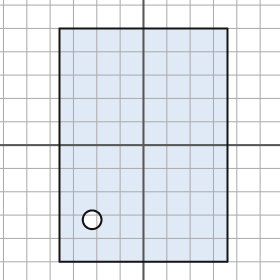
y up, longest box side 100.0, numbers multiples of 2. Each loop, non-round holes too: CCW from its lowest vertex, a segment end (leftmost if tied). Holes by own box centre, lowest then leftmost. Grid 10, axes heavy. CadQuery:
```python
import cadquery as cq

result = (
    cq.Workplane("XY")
    .moveTo(-36.0, -50.0)
    .lineTo(36.0, -50.0)
    .lineTo(36.0, 50.0)
    .lineTo(-36.0, 50.0)
    .close()
    .moveTo(-22.0, -32.0)
    .circle(4.0)
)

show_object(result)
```